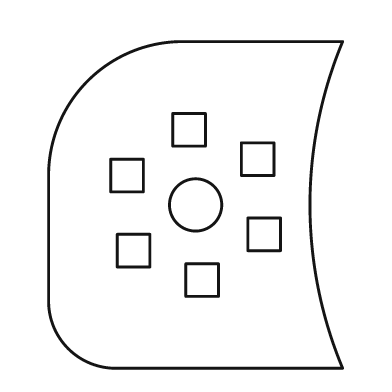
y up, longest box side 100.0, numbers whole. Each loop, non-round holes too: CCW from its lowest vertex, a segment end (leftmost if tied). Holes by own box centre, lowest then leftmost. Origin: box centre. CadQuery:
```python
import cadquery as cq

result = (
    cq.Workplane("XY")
    .moveTo(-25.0, -50.0)
    .lineTo(45.0, -50.0)
    .threePointArc((35.0, 0.0), (45.0, 50.0))
    .lineTo(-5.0, 50.0)
    .threePointArc((-33.0, 38.0), (-45.0, 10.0))
    .lineTo(-45.0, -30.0)
    .threePointArc((-39.0, -44.0), (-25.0, -50.0))
    .close()
    .moveTo(-3.0, -28.0)
    .lineTo(7.0, -28.0)
    .lineTo(7.0, -18.0)
    .lineTo(-3.0, -18.0)
    .close()
    .moveTo(-24.0, -19.0)
    .lineTo(-14.0, -19.0)
    .lineTo(-14.0, -9.0)
    .lineTo(-24.0, -9.0)
    .close()
    .moveTo(16.0, -14.0)
    .lineTo(26.0, -14.0)
    .lineTo(26.0, -4.0)
    .lineTo(16.0, -4.0)
    .close()
    .moveTo(0.0, 0.0)
    .circle(8.0)
    .moveTo(-26.0, 4.0)
    .lineTo(-16.0, 4.0)
    .lineTo(-16.0, 14.0)
    .lineTo(-26.0, 14.0)
    .close()
    .moveTo(14.0, 9.0)
    .lineTo(24.0, 9.0)
    .lineTo(24.0, 19.0)
    .lineTo(14.0, 19.0)
    .close()
    .moveTo(-7.0, 18.0)
    .lineTo(3.0, 18.0)
    .lineTo(3.0, 28.0)
    .lineTo(-7.0, 28.0)
    .close()
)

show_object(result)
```